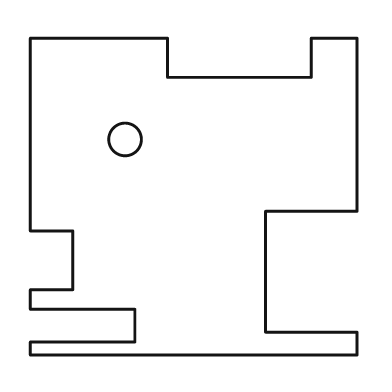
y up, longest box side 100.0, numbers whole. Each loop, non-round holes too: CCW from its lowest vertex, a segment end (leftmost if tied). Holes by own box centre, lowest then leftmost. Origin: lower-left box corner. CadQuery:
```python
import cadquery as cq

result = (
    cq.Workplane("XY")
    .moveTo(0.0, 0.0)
    .lineTo(100.0, 0.0)
    .lineTo(100.0, 7.0)
    .lineTo(72.0, 7.0)
    .lineTo(72.0, 44.0)
    .lineTo(100.0, 44.0)
    .lineTo(100.0, 97.0)
    .lineTo(86.0, 97.0)
    .lineTo(86.0, 85.0)
    .lineTo(42.0, 85.0)
    .lineTo(42.0, 97.0)
    .lineTo(0.0, 97.0)
    .lineTo(0.0, 38.0)
    .lineTo(13.0, 38.0)
    .lineTo(13.0, 20.0)
    .lineTo(0.0, 20.0)
    .lineTo(0.0, 14.0)
    .lineTo(32.0, 14.0)
    .lineTo(32.0, 4.0)
    .lineTo(0.0, 4.0)
    .close()
    .moveTo(29.0, 66.0)
    .circle(5.0)
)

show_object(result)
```